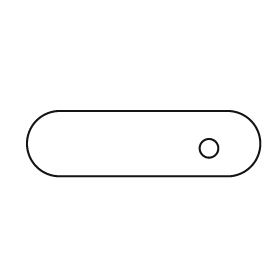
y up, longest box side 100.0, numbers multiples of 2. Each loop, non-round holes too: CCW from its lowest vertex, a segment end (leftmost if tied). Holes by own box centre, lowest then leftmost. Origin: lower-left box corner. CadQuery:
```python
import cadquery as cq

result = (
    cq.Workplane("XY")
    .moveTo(14.0, 0.0)
    .lineTo(86.0, 0.0)
    .threePointArc((100.0, 14.0), (86.0, 28.0))
    .lineTo(14.0, 28.0)
    .threePointArc((0.0, 14.0), (14.0, 0.0))
    .close()
    .moveTo(78.0, 12.0)
    .circle(4.0)
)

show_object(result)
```